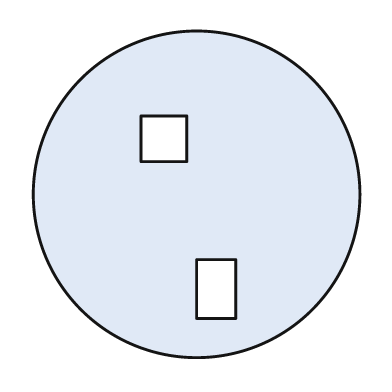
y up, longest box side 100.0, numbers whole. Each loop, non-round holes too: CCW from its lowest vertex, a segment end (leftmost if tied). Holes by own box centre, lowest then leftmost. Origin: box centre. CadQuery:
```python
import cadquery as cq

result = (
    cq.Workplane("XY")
    .moveTo(0.0, 0.0)
    .circle(50.0)
    .moveTo(0.0, -38.0)
    .lineTo(12.0, -38.0)
    .lineTo(12.0, -20.0)
    .lineTo(0.0, -20.0)
    .close()
    .moveTo(-17.0, 10.0)
    .lineTo(-3.0, 10.0)
    .lineTo(-3.0, 24.0)
    .lineTo(-17.0, 24.0)
    .close()
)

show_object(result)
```